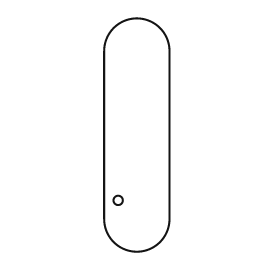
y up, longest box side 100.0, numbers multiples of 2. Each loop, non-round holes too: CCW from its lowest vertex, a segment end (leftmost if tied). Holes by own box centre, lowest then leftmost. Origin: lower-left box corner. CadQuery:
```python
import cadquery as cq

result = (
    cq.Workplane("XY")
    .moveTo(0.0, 14.0)
    .threePointArc((14.0, 0.0), (28.0, 14.0))
    .lineTo(28.0, 86.0)
    .threePointArc((14.0, 100.0), (0.0, 86.0))
    .close()
    .moveTo(6.0, 22.0)
    .circle(2.0)
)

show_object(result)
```